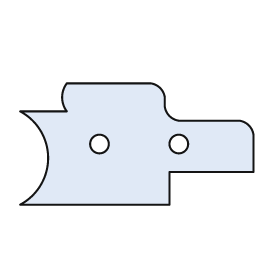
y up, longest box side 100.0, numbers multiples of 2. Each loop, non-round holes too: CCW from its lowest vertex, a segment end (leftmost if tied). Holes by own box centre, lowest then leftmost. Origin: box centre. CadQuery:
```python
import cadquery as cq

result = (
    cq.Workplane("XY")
    .moveTo(-50.0, -26.0)
    .lineTo(14.0, -26.0)
    .lineTo(14.0, -12.0)
    .lineTo(50.0, -12.0)
    .lineTo(50.0, 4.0)
    .threePointArc((48.0, 8.0), (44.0, 10.0))
    .lineTo(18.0, 10.0)
    .threePointArc((14.0, 12.0), (12.0, 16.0))
    .lineTo(12.0, 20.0)
    .threePointArc((10.0, 24.0), (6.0, 26.0))
    .lineTo(-30.0, 26.0)
    .threePointArc((-32.0, 20.0), (-30.0, 14.0))
    .lineTo(-50.0, 14.0)
    .threePointArc((-38.0, -6.0), (-50.0, -26.0))
    .close()
    .moveTo(-16.0, 0.0)
    .circle(4.0)
    .moveTo(18.0, 0.0)
    .circle(4.0)
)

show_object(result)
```